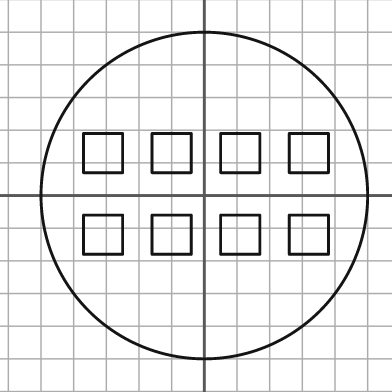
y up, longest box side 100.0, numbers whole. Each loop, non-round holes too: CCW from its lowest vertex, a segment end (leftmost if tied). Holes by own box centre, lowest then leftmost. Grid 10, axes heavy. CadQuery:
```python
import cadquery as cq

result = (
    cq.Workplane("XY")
    .moveTo(0.0, 0.0)
    .circle(50.0)
    .moveTo(-37.0, -18.0)
    .lineTo(-25.0, -18.0)
    .lineTo(-25.0, -6.0)
    .lineTo(-37.0, -6.0)
    .close()
    .moveTo(-16.0, -18.0)
    .lineTo(-4.0, -18.0)
    .lineTo(-4.0, -6.0)
    .lineTo(-16.0, -6.0)
    .close()
    .moveTo(5.0, -18.0)
    .lineTo(17.0, -18.0)
    .lineTo(17.0, -6.0)
    .lineTo(5.0, -6.0)
    .close()
    .moveTo(26.0, -18.0)
    .lineTo(38.0, -18.0)
    .lineTo(38.0, -6.0)
    .lineTo(26.0, -6.0)
    .close()
    .moveTo(-37.0, 7.0)
    .lineTo(-25.0, 7.0)
    .lineTo(-25.0, 19.0)
    .lineTo(-37.0, 19.0)
    .close()
    .moveTo(-16.0, 7.0)
    .lineTo(-4.0, 7.0)
    .lineTo(-4.0, 19.0)
    .lineTo(-16.0, 19.0)
    .close()
    .moveTo(5.0, 7.0)
    .lineTo(17.0, 7.0)
    .lineTo(17.0, 19.0)
    .lineTo(5.0, 19.0)
    .close()
    .moveTo(26.0, 7.0)
    .lineTo(38.0, 7.0)
    .lineTo(38.0, 19.0)
    .lineTo(26.0, 19.0)
    .close()
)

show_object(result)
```